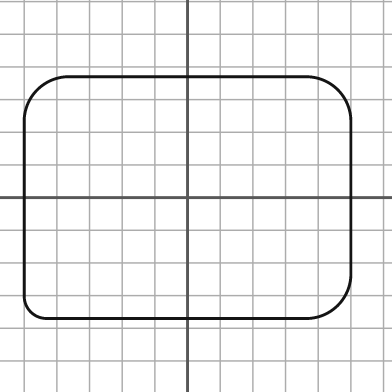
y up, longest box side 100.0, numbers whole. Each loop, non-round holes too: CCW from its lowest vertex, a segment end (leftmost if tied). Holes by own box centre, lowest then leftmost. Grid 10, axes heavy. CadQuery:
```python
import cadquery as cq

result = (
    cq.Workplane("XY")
    .moveTo(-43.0, -37.0)
    .lineTo(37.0, -37.0)
    .threePointArc((46.0, -33.0), (50.0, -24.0))
    .lineTo(50.0, 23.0)
    .threePointArc((46.0, 33.0), (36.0, 37.0))
    .lineTo(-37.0, 37.0)
    .threePointArc((-46.0, 33.0), (-50.0, 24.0))
    .lineTo(-50.0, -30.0)
    .threePointArc((-48.0, -35.0), (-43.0, -37.0))
    .close()
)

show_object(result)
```